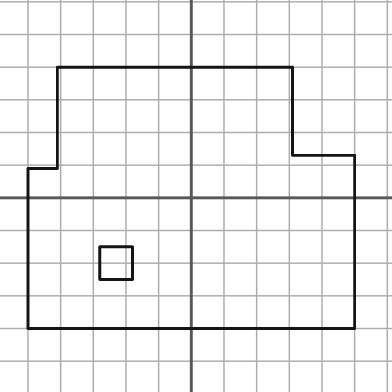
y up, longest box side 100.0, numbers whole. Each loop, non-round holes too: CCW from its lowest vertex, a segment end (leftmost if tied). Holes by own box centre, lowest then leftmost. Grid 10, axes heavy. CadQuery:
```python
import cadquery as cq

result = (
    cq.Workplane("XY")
    .moveTo(-50.0, -40.0)
    .lineTo(50.0, -40.0)
    .lineTo(50.0, 13.0)
    .lineTo(31.0, 13.0)
    .lineTo(31.0, 40.0)
    .lineTo(-41.0, 40.0)
    .lineTo(-41.0, 9.0)
    .lineTo(-50.0, 9.0)
    .close()
    .moveTo(-28.0, -25.0)
    .lineTo(-18.0, -25.0)
    .lineTo(-18.0, -15.0)
    .lineTo(-28.0, -15.0)
    .close()
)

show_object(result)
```